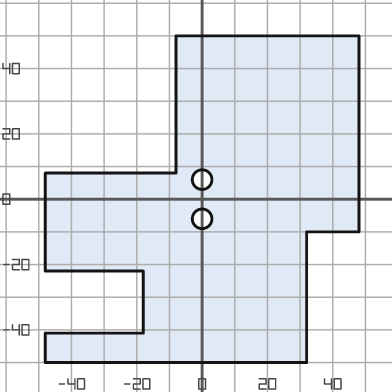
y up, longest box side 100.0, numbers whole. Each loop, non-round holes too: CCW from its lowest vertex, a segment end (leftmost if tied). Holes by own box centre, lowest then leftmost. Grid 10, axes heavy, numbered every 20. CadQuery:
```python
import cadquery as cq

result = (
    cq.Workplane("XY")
    .moveTo(-48.0, -50.0)
    .lineTo(32.0, -50.0)
    .lineTo(32.0, -10.0)
    .lineTo(48.0, -10.0)
    .lineTo(48.0, 50.0)
    .lineTo(-8.0, 50.0)
    .lineTo(-8.0, 8.0)
    .lineTo(-48.0, 8.0)
    .lineTo(-48.0, -22.0)
    .lineTo(-18.0, -22.0)
    .lineTo(-18.0, -41.0)
    .lineTo(-48.0, -41.0)
    .close()
    .moveTo(0.0, -6.0)
    .circle(3.0)
    .moveTo(0.0, 6.0)
    .circle(3.0)
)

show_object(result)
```